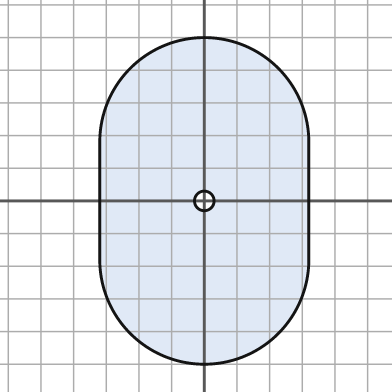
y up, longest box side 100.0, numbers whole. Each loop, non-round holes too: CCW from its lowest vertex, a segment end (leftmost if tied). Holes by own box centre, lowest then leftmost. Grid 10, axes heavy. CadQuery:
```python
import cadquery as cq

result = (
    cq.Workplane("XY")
    .moveTo(-32.0, -18.0)
    .threePointArc((0.0, -50.0), (32.0, -18.0))
    .lineTo(32.0, 18.0)
    .threePointArc((0.0, 50.0), (-32.0, 18.0))
    .close()
    .moveTo(0.0, 0.0)
    .circle(3.0)
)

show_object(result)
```